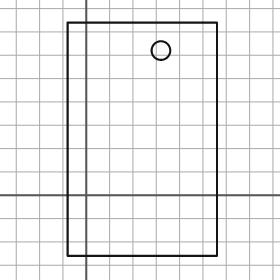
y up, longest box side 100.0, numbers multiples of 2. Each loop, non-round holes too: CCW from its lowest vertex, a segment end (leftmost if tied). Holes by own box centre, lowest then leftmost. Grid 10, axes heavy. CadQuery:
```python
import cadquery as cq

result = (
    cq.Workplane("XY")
    .moveTo(-8.0, -26.0)
    .lineTo(56.0, -26.0)
    .lineTo(56.0, 74.0)
    .lineTo(-8.0, 74.0)
    .close()
    .moveTo(32.0, 62.0)
    .circle(4.0)
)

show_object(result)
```